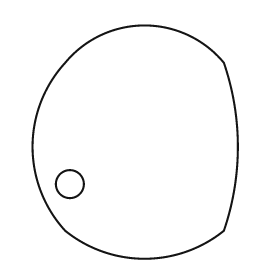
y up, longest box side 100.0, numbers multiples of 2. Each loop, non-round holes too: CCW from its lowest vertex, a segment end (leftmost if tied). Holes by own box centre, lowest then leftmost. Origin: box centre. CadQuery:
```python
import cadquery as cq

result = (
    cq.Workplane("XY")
    .moveTo(-30.0, -38.0)
    .threePointArc((4.0, -50.0), (38.0, -38.0))
    .threePointArc((44.0, -2.0), (38.0, 34.0))
    .threePointArc((4.0, 50.0), (-30.0, 34.0))
    .threePointArc((-44.0, -2.0), (-30.0, -38.0))
    .close()
    .moveTo(-28.0, -18.0)
    .circle(6.0)
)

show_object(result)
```